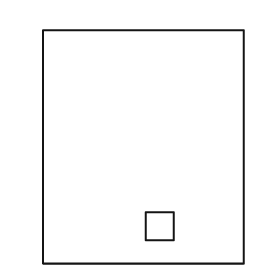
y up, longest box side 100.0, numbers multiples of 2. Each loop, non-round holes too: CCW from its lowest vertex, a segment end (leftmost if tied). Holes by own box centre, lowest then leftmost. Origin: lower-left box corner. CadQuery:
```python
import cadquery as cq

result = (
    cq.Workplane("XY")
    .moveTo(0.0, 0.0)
    .lineTo(86.0, 0.0)
    .lineTo(86.0, 100.0)
    .lineTo(0.0, 100.0)
    .close()
    .moveTo(44.0, 10.0)
    .lineTo(56.0, 10.0)
    .lineTo(56.0, 22.0)
    .lineTo(44.0, 22.0)
    .close()
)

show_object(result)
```